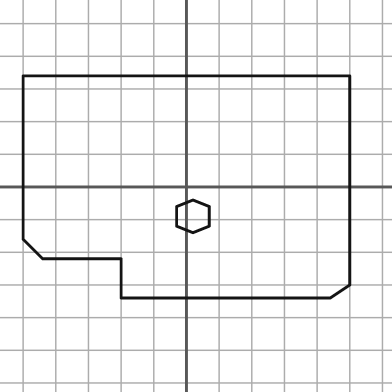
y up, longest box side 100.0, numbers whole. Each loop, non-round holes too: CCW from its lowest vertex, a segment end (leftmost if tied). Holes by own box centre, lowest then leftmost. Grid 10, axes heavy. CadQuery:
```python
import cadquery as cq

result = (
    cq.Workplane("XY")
    .moveTo(-20.0, -34.0)
    .lineTo(44.0, -34.0)
    .lineTo(50.0, -30.0)
    .lineTo(50.0, 34.0)
    .lineTo(-50.0, 34.0)
    .lineTo(-50.0, -16.0)
    .lineTo(-44.0, -22.0)
    .lineTo(-20.0, -22.0)
    .close()
    .moveTo(2.0, -14.0)
    .lineTo(7.0, -12.0)
    .lineTo(7.0, -6.0)
    .lineTo(2.0, -4.0)
    .lineTo(-3.0, -6.0)
    .lineTo(-3.0, -12.0)
    .close()
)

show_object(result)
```